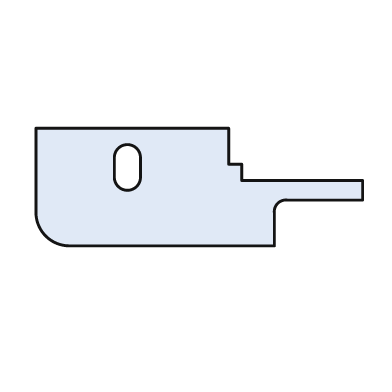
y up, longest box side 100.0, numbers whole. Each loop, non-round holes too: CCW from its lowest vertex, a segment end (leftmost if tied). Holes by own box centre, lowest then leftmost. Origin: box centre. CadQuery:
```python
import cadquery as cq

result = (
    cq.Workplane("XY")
    .moveTo(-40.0, -18.0)
    .lineTo(23.0, -18.0)
    .lineTo(23.0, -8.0)
    .threePointArc((24.0, -5.0), (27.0, -4.0))
    .lineTo(50.0, -4.0)
    .lineTo(50.0, 2.0)
    .lineTo(13.0, 2.0)
    .lineTo(13.0, 7.0)
    .lineTo(9.0, 7.0)
    .lineTo(9.0, 18.0)
    .lineTo(-50.0, 18.0)
    .lineTo(-50.0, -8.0)
    .threePointArc((-47.0, -15.0), (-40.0, -18.0))
    .close()
    .moveTo(-26.0, 3.0)
    .threePointArc((-22.0, -1.0), (-18.0, 3.0))
    .lineTo(-18.0, 9.0)
    .threePointArc((-22.0, 13.0), (-26.0, 9.0))
    .close()
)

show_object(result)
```